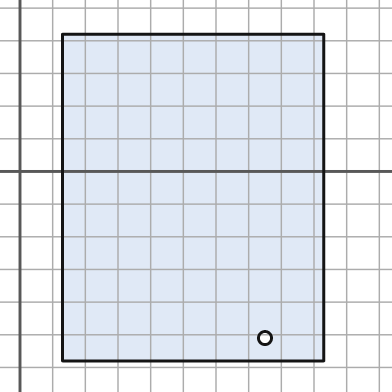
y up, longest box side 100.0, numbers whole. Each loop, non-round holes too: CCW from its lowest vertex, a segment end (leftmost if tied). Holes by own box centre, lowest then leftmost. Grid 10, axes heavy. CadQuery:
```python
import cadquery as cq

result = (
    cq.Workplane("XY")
    .moveTo(13.0, -58.0)
    .lineTo(93.0, -58.0)
    .lineTo(93.0, 42.0)
    .lineTo(13.0, 42.0)
    .close()
    .moveTo(75.0, -51.0)
    .circle(2.0)
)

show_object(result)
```